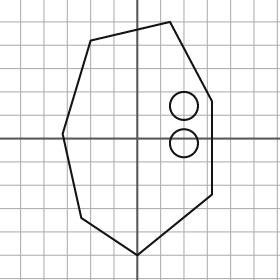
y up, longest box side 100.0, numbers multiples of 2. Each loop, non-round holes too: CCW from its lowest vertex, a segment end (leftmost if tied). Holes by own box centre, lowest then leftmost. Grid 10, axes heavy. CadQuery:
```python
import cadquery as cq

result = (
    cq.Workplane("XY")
    .moveTo(0.0, -50.0)
    .lineTo(32.0, -24.0)
    .lineTo(32.0, 16.0)
    .lineTo(14.0, 50.0)
    .lineTo(-20.0, 42.0)
    .lineTo(-32.0, 2.0)
    .lineTo(-24.0, -34.0)
    .close()
    .moveTo(20.0, -2.0)
    .circle(6.0)
    .moveTo(20.0, 14.0)
    .circle(6.0)
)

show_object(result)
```